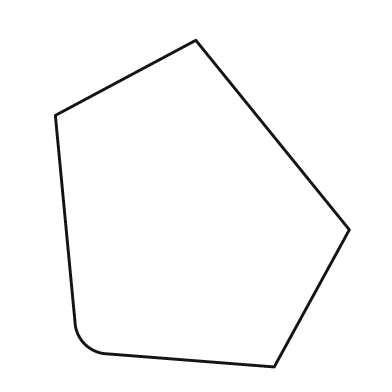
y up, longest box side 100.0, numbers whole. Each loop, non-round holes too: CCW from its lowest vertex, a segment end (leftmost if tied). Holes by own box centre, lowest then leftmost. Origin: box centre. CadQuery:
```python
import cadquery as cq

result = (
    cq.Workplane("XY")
    .moveTo(22.0, -50.0)
    .lineTo(45.0, -8.0)
    .lineTo(-2.0, 50.0)
    .lineTo(-45.0, 27.0)
    .lineTo(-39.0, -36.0)
    .threePointArc((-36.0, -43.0), (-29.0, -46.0))
    .close()
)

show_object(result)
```